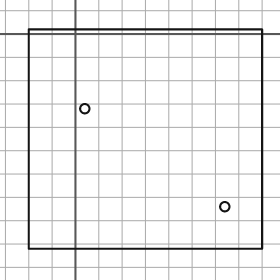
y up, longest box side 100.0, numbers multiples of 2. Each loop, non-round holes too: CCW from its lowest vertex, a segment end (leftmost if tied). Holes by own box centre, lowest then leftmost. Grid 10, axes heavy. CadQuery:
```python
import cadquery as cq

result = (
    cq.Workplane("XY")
    .moveTo(-20.0, -92.0)
    .lineTo(80.0, -92.0)
    .lineTo(80.0, 2.0)
    .lineTo(-20.0, 2.0)
    .close()
    .moveTo(64.0, -74.0)
    .circle(2.0)
    .moveTo(4.0, -32.0)
    .circle(2.0)
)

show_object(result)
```